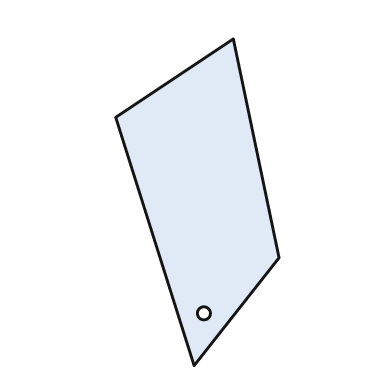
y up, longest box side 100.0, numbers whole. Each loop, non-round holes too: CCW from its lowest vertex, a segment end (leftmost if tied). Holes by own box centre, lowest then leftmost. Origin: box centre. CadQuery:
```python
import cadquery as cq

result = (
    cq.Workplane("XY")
    .moveTo(-1.0, -50.0)
    .lineTo(25.0, -17.0)
    .lineTo(11.0, 50.0)
    .lineTo(-25.0, 26.0)
    .close()
    .moveTo(2.0, -34.0)
    .circle(2.0)
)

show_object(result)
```